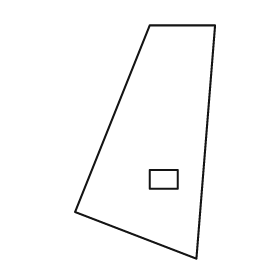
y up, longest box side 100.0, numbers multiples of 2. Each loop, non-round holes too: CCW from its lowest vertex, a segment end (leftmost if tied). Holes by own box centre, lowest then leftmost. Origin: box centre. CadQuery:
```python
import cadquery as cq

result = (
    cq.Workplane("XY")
    .moveTo(22.0, -50.0)
    .lineTo(30.0, 50.0)
    .lineTo(2.0, 50.0)
    .lineTo(-30.0, -30.0)
    .close()
    .moveTo(2.0, -20.0)
    .lineTo(14.0, -20.0)
    .lineTo(14.0, -12.0)
    .lineTo(2.0, -12.0)
    .close()
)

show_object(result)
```